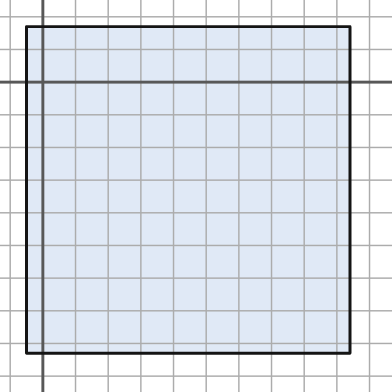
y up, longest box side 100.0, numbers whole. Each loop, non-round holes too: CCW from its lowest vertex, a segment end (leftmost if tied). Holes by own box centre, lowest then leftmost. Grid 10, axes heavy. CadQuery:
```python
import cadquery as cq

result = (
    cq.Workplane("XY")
    .moveTo(-5.0, -83.0)
    .lineTo(94.0, -83.0)
    .lineTo(94.0, 17.0)
    .lineTo(-5.0, 17.0)
    .close()
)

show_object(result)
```